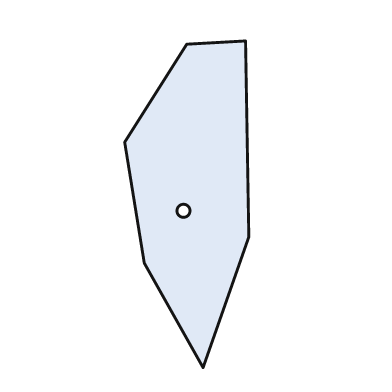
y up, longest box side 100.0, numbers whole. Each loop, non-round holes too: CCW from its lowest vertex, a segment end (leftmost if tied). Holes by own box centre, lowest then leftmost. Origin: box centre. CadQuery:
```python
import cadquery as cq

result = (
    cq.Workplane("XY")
    .moveTo(5.0, -50.0)
    .lineTo(19.0, -10.0)
    .lineTo(18.0, 50.0)
    .lineTo(0.0, 49.0)
    .lineTo(-19.0, 19.0)
    .lineTo(-13.0, -18.0)
    .close()
    .moveTo(-1.0, -2.0)
    .circle(2.0)
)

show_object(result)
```